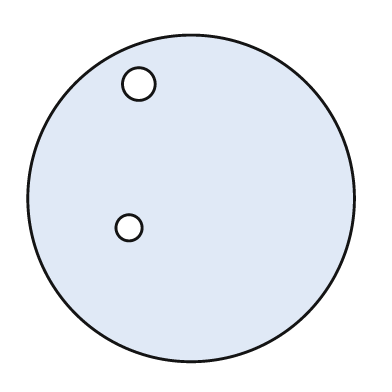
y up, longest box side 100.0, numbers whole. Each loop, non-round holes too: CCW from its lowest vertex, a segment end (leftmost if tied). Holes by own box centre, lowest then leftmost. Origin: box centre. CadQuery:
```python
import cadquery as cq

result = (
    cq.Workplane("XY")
    .moveTo(0.0, 0.0)
    .circle(50.0)
    .moveTo(-19.0, -9.0)
    .circle(4.0)
    .moveTo(-16.0, 35.0)
    .circle(5.0)
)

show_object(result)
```